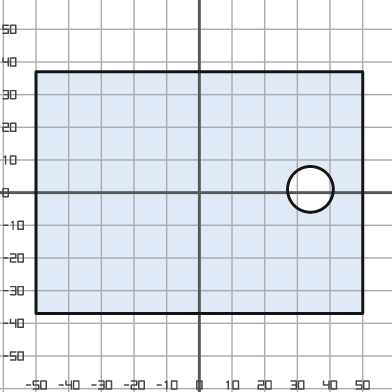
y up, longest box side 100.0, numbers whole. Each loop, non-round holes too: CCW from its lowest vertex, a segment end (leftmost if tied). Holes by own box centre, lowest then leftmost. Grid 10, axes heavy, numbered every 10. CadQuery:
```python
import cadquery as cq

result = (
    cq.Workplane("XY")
    .moveTo(-50.0, -37.0)
    .lineTo(50.0, -37.0)
    .lineTo(50.0, 37.0)
    .lineTo(-50.0, 37.0)
    .close()
    .moveTo(34.0, 1.0)
    .circle(7.0)
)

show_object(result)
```